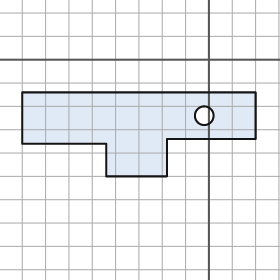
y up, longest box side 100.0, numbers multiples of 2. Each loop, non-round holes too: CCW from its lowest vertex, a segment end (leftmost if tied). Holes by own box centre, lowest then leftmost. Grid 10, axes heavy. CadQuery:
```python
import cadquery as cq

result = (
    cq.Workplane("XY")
    .moveTo(-44.0, -50.0)
    .lineTo(-18.0, -50.0)
    .lineTo(-18.0, -34.0)
    .lineTo(20.0, -34.0)
    .lineTo(20.0, -14.0)
    .lineTo(-80.0, -14.0)
    .lineTo(-80.0, -36.0)
    .lineTo(-44.0, -36.0)
    .close()
    .moveTo(-2.0, -24.0)
    .circle(4.0)
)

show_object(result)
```